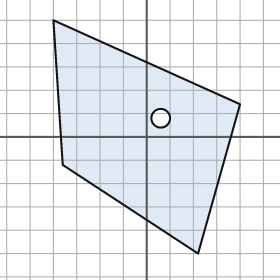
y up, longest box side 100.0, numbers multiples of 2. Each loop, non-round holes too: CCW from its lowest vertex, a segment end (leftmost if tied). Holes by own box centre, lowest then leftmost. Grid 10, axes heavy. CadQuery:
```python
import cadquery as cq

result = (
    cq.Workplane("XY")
    .moveTo(22.0, -50.0)
    .lineTo(40.0, 14.0)
    .lineTo(-40.0, 50.0)
    .lineTo(-36.0, -12.0)
    .close()
    .moveTo(6.0, 8.0)
    .circle(4.0)
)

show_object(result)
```